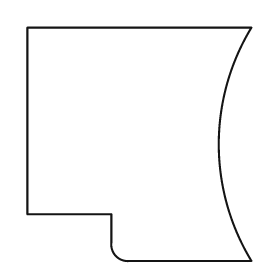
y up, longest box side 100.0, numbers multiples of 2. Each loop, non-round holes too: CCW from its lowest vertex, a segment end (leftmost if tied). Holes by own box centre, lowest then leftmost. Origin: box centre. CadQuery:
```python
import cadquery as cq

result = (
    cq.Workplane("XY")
    .moveTo(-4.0, -50.0)
    .lineTo(48.0, -50.0)
    .threePointArc((34.0, 0.0), (48.0, 50.0))
    .lineTo(-48.0, 50.0)
    .lineTo(-48.0, -30.0)
    .lineTo(-12.0, -30.0)
    .lineTo(-12.0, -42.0)
    .threePointArc((-10.0, -48.0), (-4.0, -50.0))
    .close()
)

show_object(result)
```